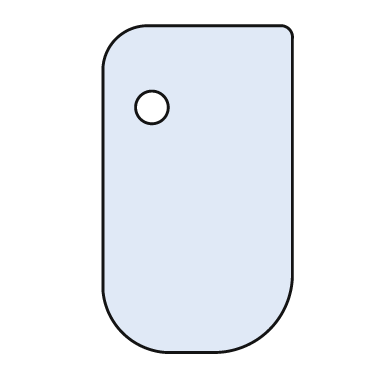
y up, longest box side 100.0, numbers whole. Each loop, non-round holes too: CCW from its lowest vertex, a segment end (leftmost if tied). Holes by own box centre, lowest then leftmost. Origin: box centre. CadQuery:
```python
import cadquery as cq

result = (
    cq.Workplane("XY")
    .moveTo(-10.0, -50.0)
    .lineTo(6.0, -50.0)
    .threePointArc((22.0, -43.0), (29.0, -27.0))
    .lineTo(29.0, 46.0)
    .threePointArc((28.0, 49.0), (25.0, 50.0))
    .lineTo(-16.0, 50.0)
    .threePointArc((-25.0, 46.0), (-29.0, 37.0))
    .lineTo(-29.0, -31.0)
    .threePointArc((-23.0, -44.0), (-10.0, -50.0))
    .close()
    .moveTo(-14.0, 25.0)
    .circle(5.0)
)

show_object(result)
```